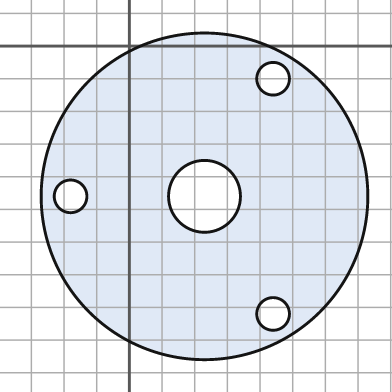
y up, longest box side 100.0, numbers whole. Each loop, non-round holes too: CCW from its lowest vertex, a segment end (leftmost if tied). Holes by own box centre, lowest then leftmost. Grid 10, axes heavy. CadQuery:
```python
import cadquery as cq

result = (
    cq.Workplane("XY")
    .moveTo(23.0, -46.0)
    .circle(50.0)
    .moveTo(44.0, -82.0)
    .circle(5.0)
    .moveTo(-18.0, -46.0)
    .circle(5.0)
    .moveTo(23.0, -46.0)
    .circle(11.0)
    .moveTo(44.0, -10.0)
    .circle(5.0)
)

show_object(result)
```